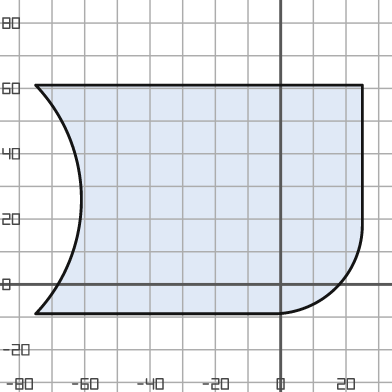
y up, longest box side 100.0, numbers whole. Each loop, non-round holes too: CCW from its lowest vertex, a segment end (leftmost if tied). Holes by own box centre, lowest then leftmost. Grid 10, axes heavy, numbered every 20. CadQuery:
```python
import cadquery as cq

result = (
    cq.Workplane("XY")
    .moveTo(-75.0, -9.0)
    .lineTo(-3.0, -9.0)
    .threePointArc((17.0, -1.0), (25.0, 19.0))
    .lineTo(25.0, 61.0)
    .lineTo(-75.0, 61.0)
    .threePointArc((-61.0, 26.0), (-75.0, -9.0))
    .close()
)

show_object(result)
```